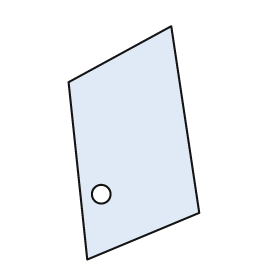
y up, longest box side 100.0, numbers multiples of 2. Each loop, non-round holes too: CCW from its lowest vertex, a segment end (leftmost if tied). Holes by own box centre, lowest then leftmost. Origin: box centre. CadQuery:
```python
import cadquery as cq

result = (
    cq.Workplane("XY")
    .moveTo(-20.0, -50.0)
    .lineTo(28.0, -30.0)
    .lineTo(16.0, 50.0)
    .lineTo(-28.0, 26.0)
    .close()
    .moveTo(-14.0, -22.0)
    .circle(4.0)
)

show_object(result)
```